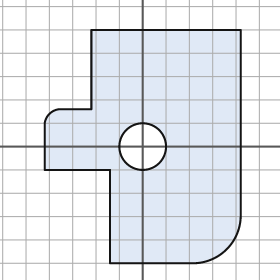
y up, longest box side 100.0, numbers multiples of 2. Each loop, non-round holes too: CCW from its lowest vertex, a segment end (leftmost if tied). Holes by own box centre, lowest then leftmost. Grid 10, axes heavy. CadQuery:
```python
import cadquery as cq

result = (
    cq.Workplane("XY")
    .moveTo(-14.0, -50.0)
    .lineTo(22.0, -50.0)
    .threePointArc((36.0, -44.0), (42.0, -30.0))
    .lineTo(42.0, 50.0)
    .lineTo(-22.0, 50.0)
    .lineTo(-22.0, 16.0)
    .lineTo(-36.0, 16.0)
    .threePointArc((-40.0, 14.0), (-42.0, 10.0))
    .lineTo(-42.0, -10.0)
    .lineTo(-14.0, -10.0)
    .close()
    .moveTo(0.0, 0.0)
    .circle(10.0)
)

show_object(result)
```